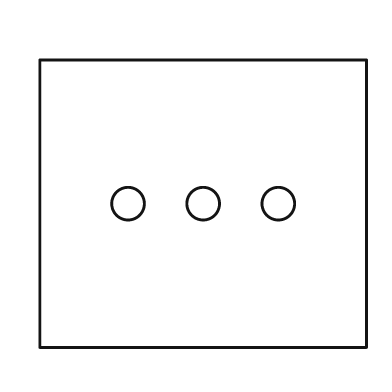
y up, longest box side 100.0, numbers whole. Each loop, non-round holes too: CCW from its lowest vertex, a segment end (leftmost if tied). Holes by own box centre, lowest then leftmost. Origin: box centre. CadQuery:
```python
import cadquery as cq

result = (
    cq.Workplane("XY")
    .moveTo(-50.0, -44.0)
    .lineTo(50.0, -44.0)
    .lineTo(50.0, 44.0)
    .lineTo(-50.0, 44.0)
    .close()
    .moveTo(-23.0, 0.0)
    .circle(5.0)
    .moveTo(0.0, 0.0)
    .circle(5.0)
    .moveTo(23.0, 0.0)
    .circle(5.0)
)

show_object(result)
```